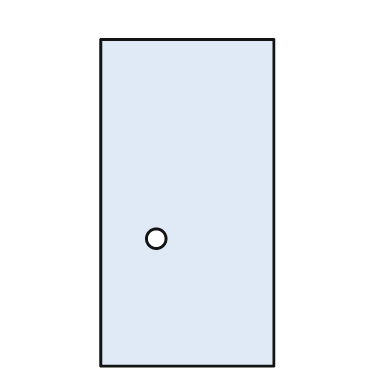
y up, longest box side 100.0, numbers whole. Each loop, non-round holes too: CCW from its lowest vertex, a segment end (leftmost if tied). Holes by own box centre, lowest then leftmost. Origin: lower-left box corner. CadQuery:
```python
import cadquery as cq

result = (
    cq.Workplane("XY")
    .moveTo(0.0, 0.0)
    .lineTo(53.0, 0.0)
    .lineTo(53.0, 100.0)
    .lineTo(0.0, 100.0)
    .close()
    .moveTo(17.0, 39.0)
    .circle(3.0)
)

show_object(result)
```